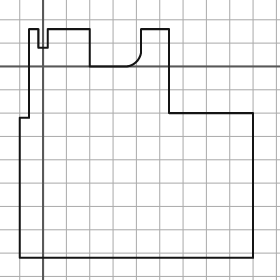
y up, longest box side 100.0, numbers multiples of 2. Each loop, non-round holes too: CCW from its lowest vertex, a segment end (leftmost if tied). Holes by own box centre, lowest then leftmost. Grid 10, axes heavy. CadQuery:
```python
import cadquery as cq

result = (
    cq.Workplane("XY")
    .moveTo(-10.0, -82.0)
    .lineTo(90.0, -82.0)
    .lineTo(90.0, -20.0)
    .lineTo(54.0, -20.0)
    .lineTo(54.0, 16.0)
    .lineTo(42.0, 16.0)
    .lineTo(42.0, 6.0)
    .threePointArc((40.0, 2.0), (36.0, 0.0))
    .lineTo(20.0, 0.0)
    .lineTo(20.0, 16.0)
    .lineTo(2.0, 16.0)
    .lineTo(2.0, 8.0)
    .lineTo(-2.0, 8.0)
    .lineTo(-2.0, 16.0)
    .lineTo(-6.0, 16.0)
    .lineTo(-6.0, -22.0)
    .lineTo(-10.0, -22.0)
    .close()
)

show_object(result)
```